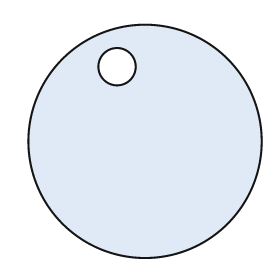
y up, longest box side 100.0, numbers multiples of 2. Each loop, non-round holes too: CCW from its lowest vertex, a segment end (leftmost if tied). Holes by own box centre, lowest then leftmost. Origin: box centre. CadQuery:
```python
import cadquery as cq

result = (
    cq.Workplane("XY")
    .moveTo(0.0, 0.0)
    .circle(50.0)
    .moveTo(-12.0, 32.0)
    .circle(8.0)
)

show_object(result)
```